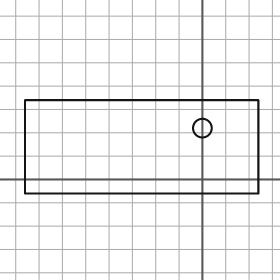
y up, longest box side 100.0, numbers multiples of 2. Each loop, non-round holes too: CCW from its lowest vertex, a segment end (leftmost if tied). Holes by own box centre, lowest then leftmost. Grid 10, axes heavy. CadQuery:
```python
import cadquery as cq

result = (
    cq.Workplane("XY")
    .moveTo(-76.0, -6.0)
    .lineTo(24.0, -6.0)
    .lineTo(24.0, 34.0)
    .lineTo(-76.0, 34.0)
    .close()
    .moveTo(0.0, 22.0)
    .circle(4.0)
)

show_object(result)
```